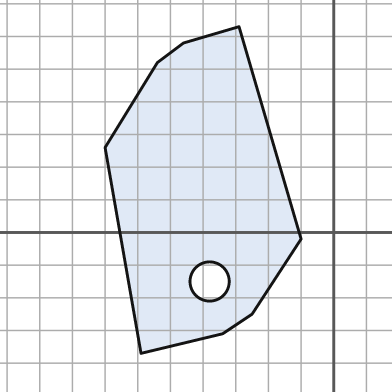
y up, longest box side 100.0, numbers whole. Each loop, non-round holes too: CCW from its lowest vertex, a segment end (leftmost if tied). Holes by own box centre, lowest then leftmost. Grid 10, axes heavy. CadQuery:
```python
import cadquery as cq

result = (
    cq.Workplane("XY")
    .moveTo(-59.0, -37.0)
    .lineTo(-34.0, -31.0)
    .lineTo(-25.0, -25.0)
    .lineTo(-10.0, -2.0)
    .lineTo(-29.0, 63.0)
    .lineTo(-46.0, 58.0)
    .lineTo(-54.0, 52.0)
    .lineTo(-70.0, 26.0)
    .close()
    .moveTo(-38.0, -15.0)
    .circle(6.0)
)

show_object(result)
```